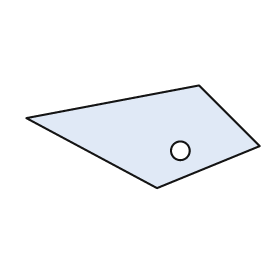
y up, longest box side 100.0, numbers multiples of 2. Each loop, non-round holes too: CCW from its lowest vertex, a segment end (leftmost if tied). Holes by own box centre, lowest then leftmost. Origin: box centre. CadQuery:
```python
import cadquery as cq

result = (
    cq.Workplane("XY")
    .moveTo(6.0, -22.0)
    .lineTo(50.0, -4.0)
    .lineTo(24.0, 22.0)
    .lineTo(-50.0, 8.0)
    .close()
    .moveTo(16.0, -6.0)
    .circle(4.0)
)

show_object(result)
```